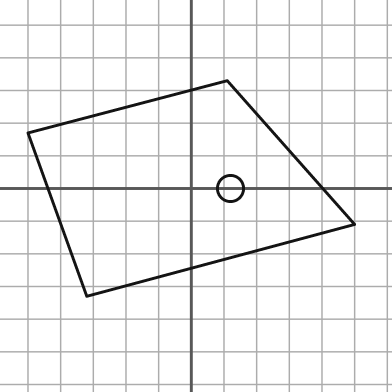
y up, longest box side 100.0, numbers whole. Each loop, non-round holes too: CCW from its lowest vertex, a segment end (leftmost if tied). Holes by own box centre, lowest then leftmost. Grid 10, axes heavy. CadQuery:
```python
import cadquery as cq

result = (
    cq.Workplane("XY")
    .moveTo(-32.0, -33.0)
    .lineTo(50.0, -11.0)
    .lineTo(11.0, 33.0)
    .lineTo(-50.0, 17.0)
    .close()
    .moveTo(12.0, 0.0)
    .circle(4.0)
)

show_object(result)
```